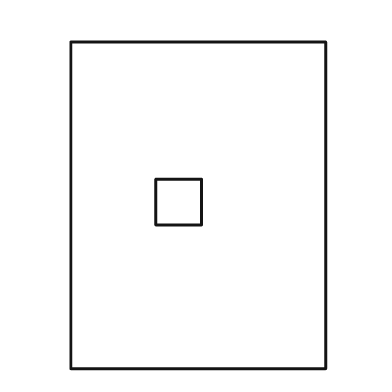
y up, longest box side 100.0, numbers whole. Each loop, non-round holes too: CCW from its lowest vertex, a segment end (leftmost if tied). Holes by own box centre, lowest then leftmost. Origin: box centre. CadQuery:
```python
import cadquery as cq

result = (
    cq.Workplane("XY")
    .moveTo(-39.0, -50.0)
    .lineTo(39.0, -50.0)
    .lineTo(39.0, 50.0)
    .lineTo(-39.0, 50.0)
    .close()
    .moveTo(-13.0, -6.0)
    .lineTo(1.0, -6.0)
    .lineTo(1.0, 8.0)
    .lineTo(-13.0, 8.0)
    .close()
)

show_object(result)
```